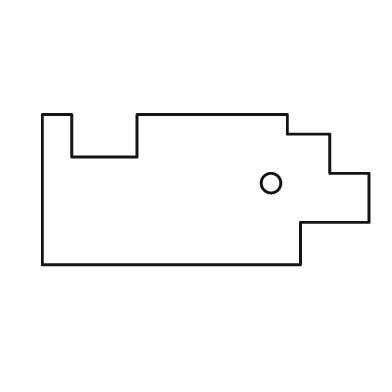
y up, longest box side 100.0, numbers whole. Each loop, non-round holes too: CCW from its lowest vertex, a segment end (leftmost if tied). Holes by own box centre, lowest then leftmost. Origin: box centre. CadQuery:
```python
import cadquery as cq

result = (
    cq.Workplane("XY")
    .moveTo(-50.0, -23.0)
    .lineTo(29.0, -23.0)
    .lineTo(29.0, -10.0)
    .lineTo(50.0, -10.0)
    .lineTo(50.0, 5.0)
    .lineTo(38.0, 5.0)
    .lineTo(38.0, 17.0)
    .lineTo(25.0, 17.0)
    .lineTo(25.0, 23.0)
    .lineTo(-21.0, 23.0)
    .lineTo(-21.0, 10.0)
    .lineTo(-41.0, 10.0)
    .lineTo(-41.0, 23.0)
    .lineTo(-50.0, 23.0)
    .close()
    .moveTo(20.0, 2.0)
    .circle(3.0)
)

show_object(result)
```